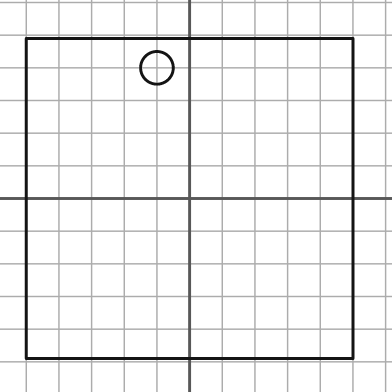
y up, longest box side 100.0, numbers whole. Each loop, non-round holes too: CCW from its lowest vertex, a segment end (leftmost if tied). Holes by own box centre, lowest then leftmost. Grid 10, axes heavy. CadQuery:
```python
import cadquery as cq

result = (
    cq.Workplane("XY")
    .moveTo(-50.0, -49.0)
    .lineTo(50.0, -49.0)
    .lineTo(50.0, 49.0)
    .lineTo(-50.0, 49.0)
    .close()
    .moveTo(-10.0, 40.0)
    .circle(5.0)
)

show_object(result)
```